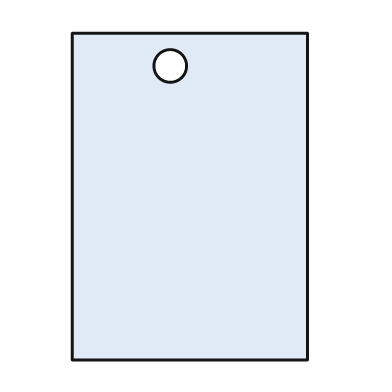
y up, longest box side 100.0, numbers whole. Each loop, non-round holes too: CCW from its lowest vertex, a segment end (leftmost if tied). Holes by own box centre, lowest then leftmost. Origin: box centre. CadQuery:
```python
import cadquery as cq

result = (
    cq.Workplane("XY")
    .moveTo(-36.0, -50.0)
    .lineTo(36.0, -50.0)
    .lineTo(36.0, 50.0)
    .lineTo(-36.0, 50.0)
    .close()
    .moveTo(-6.0, 40.0)
    .circle(5.0)
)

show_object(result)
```